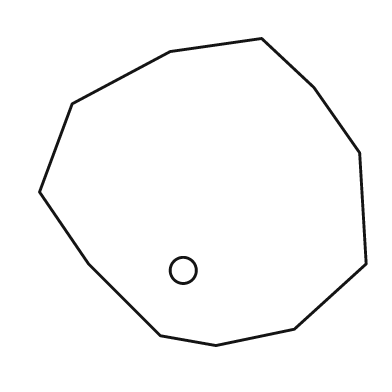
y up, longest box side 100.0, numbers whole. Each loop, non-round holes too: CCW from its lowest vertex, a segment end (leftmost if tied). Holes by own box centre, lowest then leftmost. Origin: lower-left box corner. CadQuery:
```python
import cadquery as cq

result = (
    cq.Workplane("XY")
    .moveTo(54.0, 0.0)
    .lineTo(78.0, 5.0)
    .lineTo(100.0, 25.0)
    .lineTo(98.0, 59.0)
    .lineTo(84.0, 79.0)
    .lineTo(68.0, 94.0)
    .lineTo(40.0, 90.0)
    .lineTo(10.0, 74.0)
    .lineTo(0.0, 47.0)
    .lineTo(15.0, 25.0)
    .lineTo(37.0, 3.0)
    .close()
    .moveTo(44.0, 23.0)
    .circle(4.0)
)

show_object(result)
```